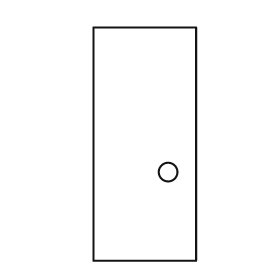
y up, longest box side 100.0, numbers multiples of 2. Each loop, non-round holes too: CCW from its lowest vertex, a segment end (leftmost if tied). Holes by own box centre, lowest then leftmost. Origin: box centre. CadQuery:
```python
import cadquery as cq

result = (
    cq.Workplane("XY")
    .moveTo(-22.0, -50.0)
    .lineTo(22.0, -50.0)
    .lineTo(22.0, 50.0)
    .lineTo(-22.0, 50.0)
    .close()
    .moveTo(10.0, -12.0)
    .circle(4.0)
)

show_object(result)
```